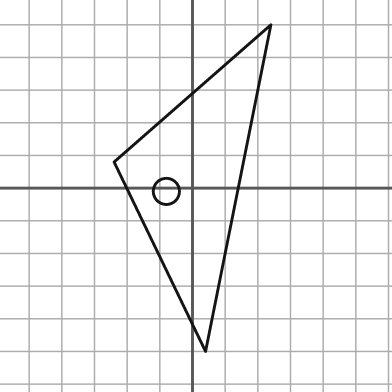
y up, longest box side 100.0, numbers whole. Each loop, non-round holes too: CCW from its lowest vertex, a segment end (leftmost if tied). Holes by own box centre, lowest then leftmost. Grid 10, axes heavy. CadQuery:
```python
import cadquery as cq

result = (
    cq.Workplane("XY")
    .moveTo(4.0, -50.0)
    .lineTo(24.0, 50.0)
    .lineTo(-24.0, 8.0)
    .close()
    .moveTo(-8.0, -1.0)
    .circle(4.0)
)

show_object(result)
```